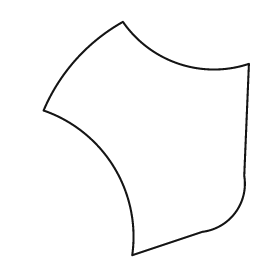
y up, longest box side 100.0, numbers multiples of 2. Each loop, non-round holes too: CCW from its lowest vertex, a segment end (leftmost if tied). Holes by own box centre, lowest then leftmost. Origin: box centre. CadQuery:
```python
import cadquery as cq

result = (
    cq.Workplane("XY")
    .moveTo(-6.0, -50.0)
    .lineTo(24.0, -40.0)
    .threePointArc((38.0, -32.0), (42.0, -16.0))
    .lineTo(44.0, 32.0)
    .threePointArc((14.0, 32.0), (-10.0, 50.0))
    .threePointArc((-30.0, 34.0), (-44.0, 12.0))
    .threePointArc((-14.0, -12.0), (-6.0, -50.0))
    .close()
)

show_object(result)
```